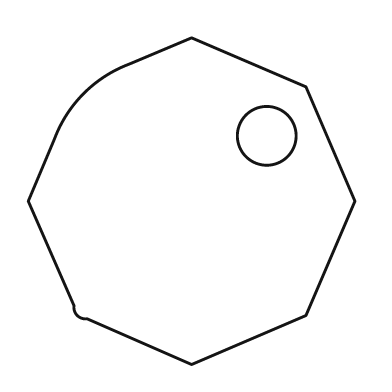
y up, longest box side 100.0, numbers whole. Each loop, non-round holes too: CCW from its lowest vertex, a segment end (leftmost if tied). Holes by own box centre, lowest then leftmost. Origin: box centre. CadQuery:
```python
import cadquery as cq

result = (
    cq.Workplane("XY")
    .moveTo(0.0, -50.0)
    .lineTo(35.0, -35.0)
    .lineTo(50.0, 0.0)
    .lineTo(35.0, 35.0)
    .lineTo(0.0, 50.0)
    .lineTo(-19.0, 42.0)
    .threePointArc((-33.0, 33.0), (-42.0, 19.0))
    .lineTo(-50.0, 0.0)
    .lineTo(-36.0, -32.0)
    .threePointArc((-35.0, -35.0), (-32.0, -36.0))
    .close()
    .moveTo(23.0, 20.0)
    .circle(9.0)
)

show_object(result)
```